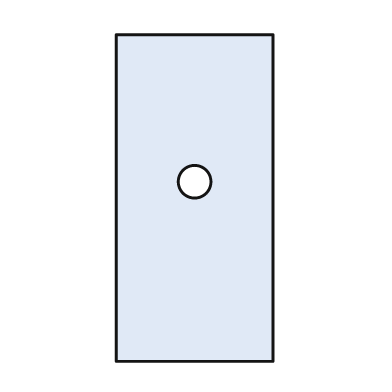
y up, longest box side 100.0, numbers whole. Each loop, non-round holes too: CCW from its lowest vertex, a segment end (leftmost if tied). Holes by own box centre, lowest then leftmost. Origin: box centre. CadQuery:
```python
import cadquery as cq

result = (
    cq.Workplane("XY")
    .moveTo(-24.0, -50.0)
    .lineTo(24.0, -50.0)
    .lineTo(24.0, 50.0)
    .lineTo(-24.0, 50.0)
    .close()
    .moveTo(0.0, 5.0)
    .circle(5.0)
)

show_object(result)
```